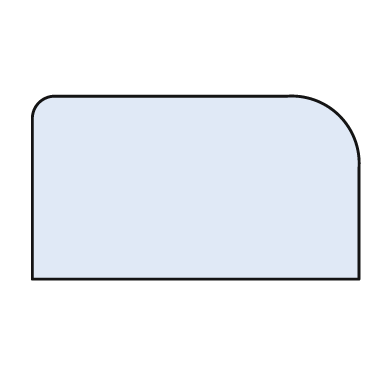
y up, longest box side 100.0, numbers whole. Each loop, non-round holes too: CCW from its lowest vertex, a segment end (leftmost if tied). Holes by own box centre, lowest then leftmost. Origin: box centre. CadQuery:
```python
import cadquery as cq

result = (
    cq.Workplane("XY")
    .moveTo(-50.0, -28.0)
    .lineTo(50.0, -28.0)
    .lineTo(50.0, 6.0)
    .threePointArc((44.0, 22.0), (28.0, 28.0))
    .lineTo(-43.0, 28.0)
    .threePointArc((-48.0, 26.0), (-50.0, 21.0))
    .close()
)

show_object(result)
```